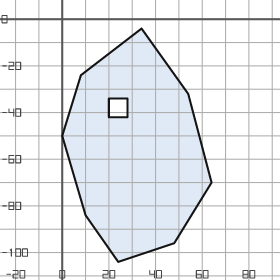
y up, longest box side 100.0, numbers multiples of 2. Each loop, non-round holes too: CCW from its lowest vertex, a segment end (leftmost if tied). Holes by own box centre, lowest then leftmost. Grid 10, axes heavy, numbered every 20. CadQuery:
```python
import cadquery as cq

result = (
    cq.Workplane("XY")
    .moveTo(24.0, -104.0)
    .lineTo(48.0, -96.0)
    .lineTo(64.0, -70.0)
    .lineTo(54.0, -32.0)
    .lineTo(34.0, -4.0)
    .lineTo(8.0, -24.0)
    .lineTo(0.0, -50.0)
    .lineTo(10.0, -84.0)
    .close()
    .moveTo(20.0, -42.0)
    .lineTo(28.0, -42.0)
    .lineTo(28.0, -34.0)
    .lineTo(20.0, -34.0)
    .close()
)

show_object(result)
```